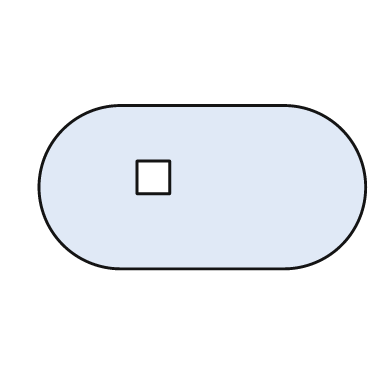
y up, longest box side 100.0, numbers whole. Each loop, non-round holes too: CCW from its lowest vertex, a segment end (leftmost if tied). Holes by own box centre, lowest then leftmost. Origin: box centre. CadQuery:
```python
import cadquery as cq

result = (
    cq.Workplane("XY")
    .moveTo(-25.0, -25.0)
    .lineTo(25.0, -25.0)
    .threePointArc((50.0, 0.0), (25.0, 25.0))
    .lineTo(-25.0, 25.0)
    .threePointArc((-50.0, 0.0), (-25.0, -25.0))
    .close()
    .moveTo(-20.0, -2.0)
    .lineTo(-10.0, -2.0)
    .lineTo(-10.0, 8.0)
    .lineTo(-20.0, 8.0)
    .close()
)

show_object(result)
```